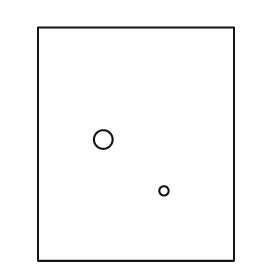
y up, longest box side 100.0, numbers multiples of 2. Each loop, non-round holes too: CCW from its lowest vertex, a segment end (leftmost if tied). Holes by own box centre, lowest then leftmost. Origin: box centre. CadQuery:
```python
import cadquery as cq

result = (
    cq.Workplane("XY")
    .moveTo(-42.0, -50.0)
    .lineTo(42.0, -50.0)
    .lineTo(42.0, 50.0)
    .lineTo(-42.0, 50.0)
    .close()
    .moveTo(12.0, -20.0)
    .circle(2.0)
    .moveTo(-14.0, 2.0)
    .circle(4.0)
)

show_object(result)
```